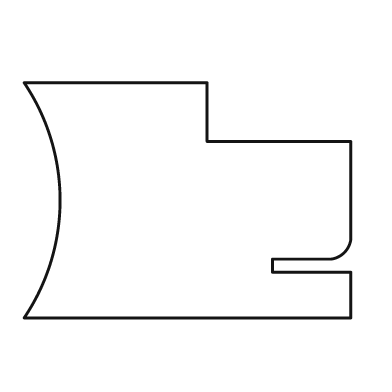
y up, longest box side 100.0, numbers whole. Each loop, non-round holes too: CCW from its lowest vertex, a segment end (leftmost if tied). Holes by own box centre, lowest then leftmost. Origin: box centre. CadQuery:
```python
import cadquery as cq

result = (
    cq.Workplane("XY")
    .moveTo(-50.0, -36.0)
    .lineTo(50.0, -36.0)
    .lineTo(50.0, -22.0)
    .lineTo(26.0, -22.0)
    .lineTo(26.0, -18.0)
    .lineTo(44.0, -18.0)
    .threePointArc((48.0, -16.0), (50.0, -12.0))
    .lineTo(50.0, 18.0)
    .lineTo(6.0, 18.0)
    .lineTo(6.0, 36.0)
    .lineTo(-50.0, 36.0)
    .threePointArc((-39.0, 0.0), (-50.0, -36.0))
    .close()
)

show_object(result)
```